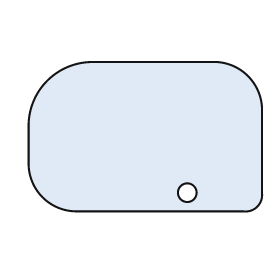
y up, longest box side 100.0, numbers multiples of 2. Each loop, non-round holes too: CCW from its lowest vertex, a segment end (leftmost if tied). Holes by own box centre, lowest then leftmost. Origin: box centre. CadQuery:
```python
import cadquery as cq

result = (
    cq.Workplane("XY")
    .moveTo(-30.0, -32.0)
    .lineTo(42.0, -32.0)
    .threePointArc((48.0, -30.0), (50.0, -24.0))
    .lineTo(50.0, 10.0)
    .threePointArc((44.0, 26.0), (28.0, 32.0))
    .lineTo(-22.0, 32.0)
    .threePointArc((-42.0, 24.0), (-50.0, 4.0))
    .lineTo(-50.0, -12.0)
    .threePointArc((-44.0, -26.0), (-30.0, -32.0))
    .close()
    .moveTo(18.0, -24.0)
    .circle(4.0)
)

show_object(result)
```